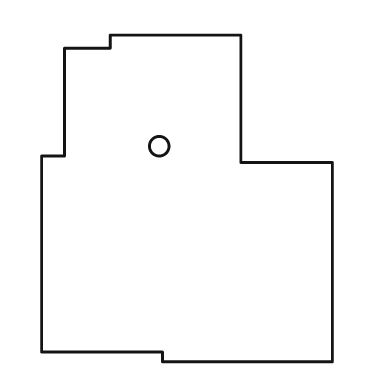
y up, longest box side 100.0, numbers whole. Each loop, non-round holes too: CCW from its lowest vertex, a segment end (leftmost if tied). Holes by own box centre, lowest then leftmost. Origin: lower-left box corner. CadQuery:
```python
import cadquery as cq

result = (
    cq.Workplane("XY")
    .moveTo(37.0, 0.0)
    .lineTo(89.0, 0.0)
    .lineTo(89.0, 61.0)
    .lineTo(61.0, 61.0)
    .lineTo(61.0, 100.0)
    .lineTo(21.0, 100.0)
    .lineTo(21.0, 96.0)
    .lineTo(7.0, 96.0)
    .lineTo(7.0, 63.0)
    .lineTo(0.0, 63.0)
    .lineTo(0.0, 3.0)
    .lineTo(37.0, 3.0)
    .close()
    .moveTo(36.0, 66.0)
    .circle(3.0)
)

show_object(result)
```